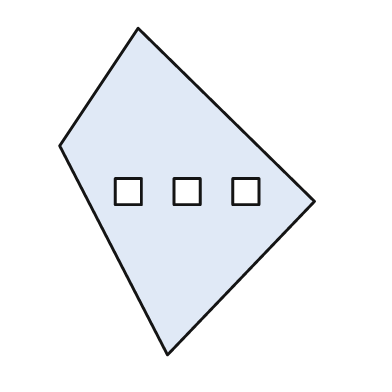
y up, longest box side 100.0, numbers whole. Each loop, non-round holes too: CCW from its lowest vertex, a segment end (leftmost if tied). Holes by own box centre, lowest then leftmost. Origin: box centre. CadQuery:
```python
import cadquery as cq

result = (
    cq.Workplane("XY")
    .moveTo(-6.0, -50.0)
    .lineTo(39.0, -3.0)
    .lineTo(-15.0, 50.0)
    .lineTo(-39.0, 14.0)
    .close()
    .moveTo(-22.0, -4.0)
    .lineTo(-14.0, -4.0)
    .lineTo(-14.0, 4.0)
    .lineTo(-22.0, 4.0)
    .close()
    .moveTo(-4.0, -4.0)
    .lineTo(4.0, -4.0)
    .lineTo(4.0, 4.0)
    .lineTo(-4.0, 4.0)
    .close()
    .moveTo(14.0, -4.0)
    .lineTo(22.0, -4.0)
    .lineTo(22.0, 4.0)
    .lineTo(14.0, 4.0)
    .close()
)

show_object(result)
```